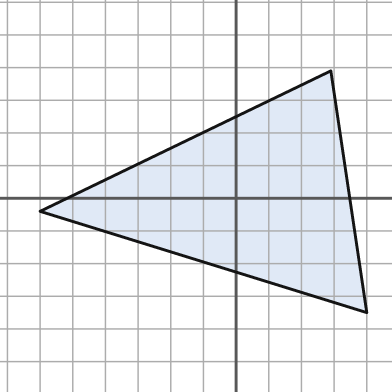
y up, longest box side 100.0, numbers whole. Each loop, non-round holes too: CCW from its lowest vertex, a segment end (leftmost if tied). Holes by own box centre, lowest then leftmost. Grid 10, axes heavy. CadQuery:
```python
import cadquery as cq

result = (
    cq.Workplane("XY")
    .moveTo(40.0, -35.0)
    .lineTo(29.0, 39.0)
    .lineTo(-60.0, -4.0)
    .close()
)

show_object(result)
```